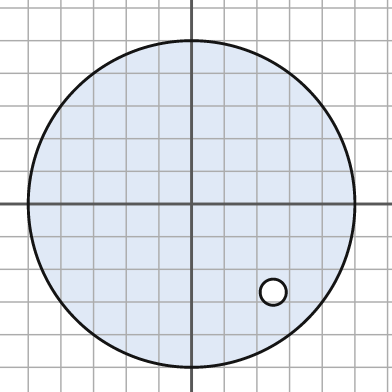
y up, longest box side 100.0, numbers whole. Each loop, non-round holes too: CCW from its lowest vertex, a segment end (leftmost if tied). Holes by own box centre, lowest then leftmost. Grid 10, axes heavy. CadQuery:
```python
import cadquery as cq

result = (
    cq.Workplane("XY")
    .moveTo(0.0, 0.0)
    .circle(50.0)
    .moveTo(25.0, -27.0)
    .circle(4.0)
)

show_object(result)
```